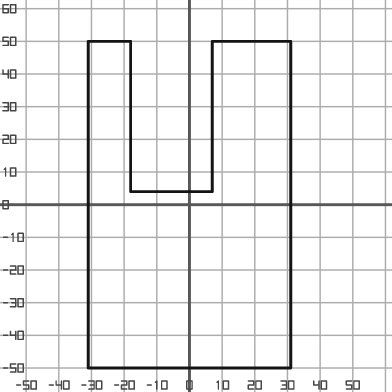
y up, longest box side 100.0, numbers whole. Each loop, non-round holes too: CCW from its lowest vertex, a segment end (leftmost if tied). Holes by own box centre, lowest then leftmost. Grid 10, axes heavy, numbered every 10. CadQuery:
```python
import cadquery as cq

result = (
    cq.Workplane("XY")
    .moveTo(-31.0, -50.0)
    .lineTo(31.0, -50.0)
    .lineTo(31.0, 50.0)
    .lineTo(7.0, 50.0)
    .lineTo(7.0, 4.0)
    .lineTo(-18.0, 4.0)
    .lineTo(-18.0, 50.0)
    .lineTo(-31.0, 50.0)
    .close()
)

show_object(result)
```